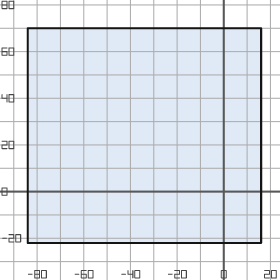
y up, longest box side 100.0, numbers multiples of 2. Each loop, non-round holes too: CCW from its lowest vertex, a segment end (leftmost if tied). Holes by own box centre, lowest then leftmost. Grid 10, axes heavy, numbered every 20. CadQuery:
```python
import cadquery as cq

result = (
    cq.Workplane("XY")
    .moveTo(-84.0, -22.0)
    .lineTo(16.0, -22.0)
    .lineTo(16.0, 70.0)
    .lineTo(-84.0, 70.0)
    .close()
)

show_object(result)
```